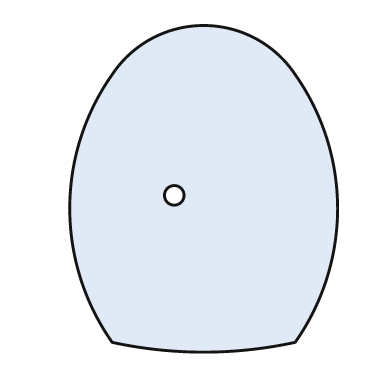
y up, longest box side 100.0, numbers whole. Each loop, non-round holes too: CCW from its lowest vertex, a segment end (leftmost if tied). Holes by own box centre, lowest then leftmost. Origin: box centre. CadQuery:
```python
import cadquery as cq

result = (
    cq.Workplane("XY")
    .moveTo(-28.0, -47.0)
    .threePointArc((0.0, -50.0), (28.0, -47.0))
    .threePointArc((41.0, -6.0), (28.0, 35.0))
    .threePointArc((0.0, 50.0), (-28.0, 35.0))
    .threePointArc((-41.0, -6.0), (-28.0, -47.0))
    .close()
    .moveTo(-9.0, -2.0)
    .circle(3.0)
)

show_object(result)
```